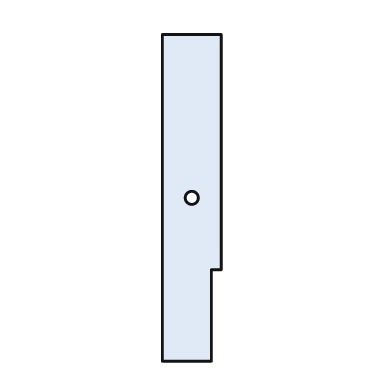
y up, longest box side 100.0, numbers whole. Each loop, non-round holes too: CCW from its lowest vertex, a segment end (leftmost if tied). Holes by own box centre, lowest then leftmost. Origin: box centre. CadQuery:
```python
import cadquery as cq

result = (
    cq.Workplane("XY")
    .moveTo(-9.0, -50.0)
    .lineTo(6.0, -50.0)
    .lineTo(6.0, -22.0)
    .lineTo(9.0, -22.0)
    .lineTo(9.0, 50.0)
    .lineTo(-9.0, 50.0)
    .close()
    .moveTo(0.0, 0.0)
    .circle(2.0)
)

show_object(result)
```